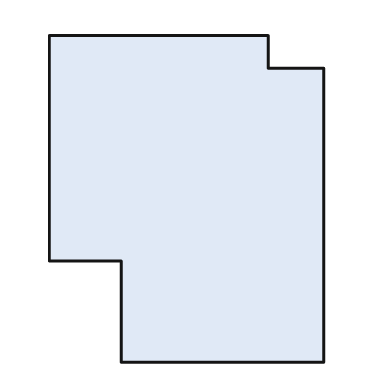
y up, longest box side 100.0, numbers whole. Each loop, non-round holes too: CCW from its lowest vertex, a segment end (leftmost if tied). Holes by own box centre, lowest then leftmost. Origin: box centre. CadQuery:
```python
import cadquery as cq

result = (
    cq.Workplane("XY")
    .moveTo(-20.0, -50.0)
    .lineTo(42.0, -50.0)
    .lineTo(42.0, 40.0)
    .lineTo(25.0, 40.0)
    .lineTo(25.0, 50.0)
    .lineTo(-42.0, 50.0)
    .lineTo(-42.0, -19.0)
    .lineTo(-20.0, -19.0)
    .close()
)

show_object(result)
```